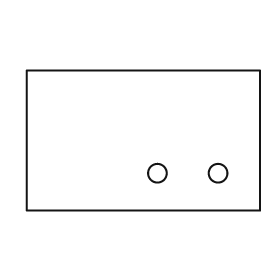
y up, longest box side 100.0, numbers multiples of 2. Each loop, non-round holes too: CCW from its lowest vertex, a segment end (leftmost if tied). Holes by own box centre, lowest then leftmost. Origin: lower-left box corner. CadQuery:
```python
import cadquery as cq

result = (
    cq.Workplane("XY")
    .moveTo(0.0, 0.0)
    .lineTo(100.0, 0.0)
    .lineTo(100.0, 60.0)
    .lineTo(0.0, 60.0)
    .close()
    .moveTo(56.0, 16.0)
    .circle(4.0)
    .moveTo(82.0, 16.0)
    .circle(4.0)
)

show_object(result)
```